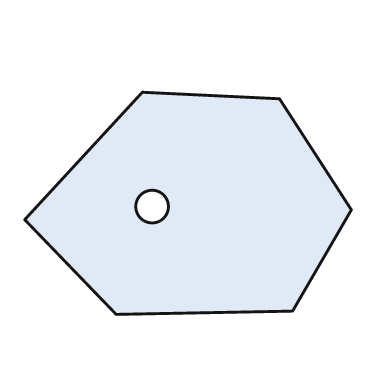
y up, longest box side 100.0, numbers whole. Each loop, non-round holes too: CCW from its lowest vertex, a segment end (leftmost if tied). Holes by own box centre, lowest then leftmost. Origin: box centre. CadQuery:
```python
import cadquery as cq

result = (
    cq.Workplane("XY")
    .moveTo(-22.0, -34.0)
    .lineTo(32.0, -33.0)
    .lineTo(50.0, -2.0)
    .lineTo(28.0, 32.0)
    .lineTo(-14.0, 34.0)
    .lineTo(-50.0, -5.0)
    .close()
    .moveTo(-11.0, -1.0)
    .circle(5.0)
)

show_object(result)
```